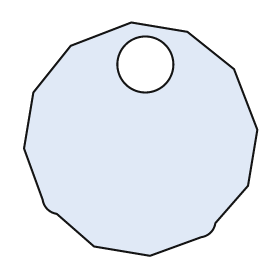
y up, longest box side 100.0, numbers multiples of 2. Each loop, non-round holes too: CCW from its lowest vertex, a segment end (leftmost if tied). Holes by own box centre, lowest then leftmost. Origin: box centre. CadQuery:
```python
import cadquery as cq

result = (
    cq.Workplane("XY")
    .moveTo(4.0, -50.0)
    .lineTo(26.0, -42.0)
    .threePointArc((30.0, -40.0), (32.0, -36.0))
    .lineTo(46.0, -20.0)
    .lineTo(50.0, 4.0)
    .lineTo(40.0, 30.0)
    .lineTo(20.0, 46.0)
    .lineTo(-4.0, 50.0)
    .lineTo(-30.0, 40.0)
    .lineTo(-46.0, 20.0)
    .lineTo(-50.0, -4.0)
    .lineTo(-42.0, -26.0)
    .threePointArc((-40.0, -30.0), (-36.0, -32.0))
    .lineTo(-20.0, -46.0)
    .close()
    .moveTo(2.0, 32.0)
    .circle(12.0)
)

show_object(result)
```